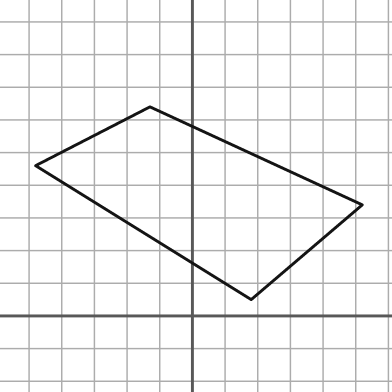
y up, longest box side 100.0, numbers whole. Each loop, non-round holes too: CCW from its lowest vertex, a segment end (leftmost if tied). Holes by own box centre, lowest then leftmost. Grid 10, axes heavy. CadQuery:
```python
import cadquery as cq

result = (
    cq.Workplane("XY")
    .moveTo(18.0, 5.0)
    .lineTo(52.0, 34.0)
    .lineTo(-13.0, 64.0)
    .lineTo(-48.0, 46.0)
    .close()
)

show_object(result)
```